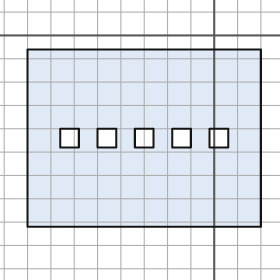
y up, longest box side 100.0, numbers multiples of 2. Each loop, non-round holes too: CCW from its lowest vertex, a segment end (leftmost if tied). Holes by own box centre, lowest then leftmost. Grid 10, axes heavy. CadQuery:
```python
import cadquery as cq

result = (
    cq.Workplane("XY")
    .moveTo(-80.0, -82.0)
    .lineTo(20.0, -82.0)
    .lineTo(20.0, -6.0)
    .lineTo(-80.0, -6.0)
    .close()
    .moveTo(-66.0, -48.0)
    .lineTo(-58.0, -48.0)
    .lineTo(-58.0, -40.0)
    .lineTo(-66.0, -40.0)
    .close()
    .moveTo(-50.0, -48.0)
    .lineTo(-42.0, -48.0)
    .lineTo(-42.0, -40.0)
    .lineTo(-50.0, -40.0)
    .close()
    .moveTo(-34.0, -48.0)
    .lineTo(-26.0, -48.0)
    .lineTo(-26.0, -40.0)
    .lineTo(-34.0, -40.0)
    .close()
    .moveTo(-18.0, -48.0)
    .lineTo(-10.0, -48.0)
    .lineTo(-10.0, -40.0)
    .lineTo(-18.0, -40.0)
    .close()
    .moveTo(-2.0, -48.0)
    .lineTo(6.0, -48.0)
    .lineTo(6.0, -40.0)
    .lineTo(-2.0, -40.0)
    .close()
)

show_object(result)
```